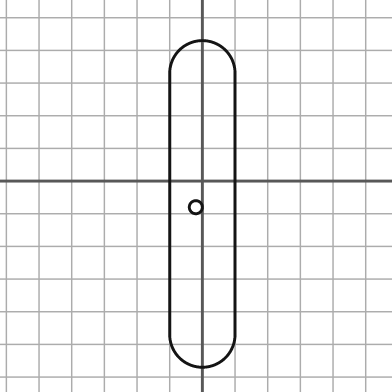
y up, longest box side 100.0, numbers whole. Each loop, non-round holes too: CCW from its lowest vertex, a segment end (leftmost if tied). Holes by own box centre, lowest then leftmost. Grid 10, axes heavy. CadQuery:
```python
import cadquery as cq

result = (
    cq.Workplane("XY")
    .moveTo(-10.0, -47.0)
    .threePointArc((0.0, -57.0), (10.0, -47.0))
    .lineTo(10.0, 33.0)
    .threePointArc((0.0, 43.0), (-10.0, 33.0))
    .close()
    .moveTo(-2.0, -8.0)
    .circle(2.0)
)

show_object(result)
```